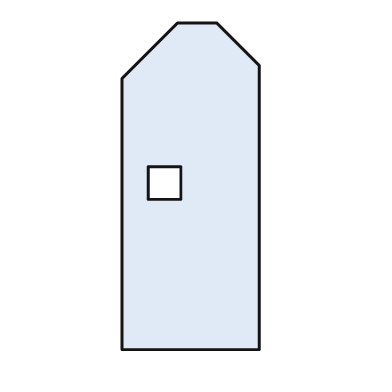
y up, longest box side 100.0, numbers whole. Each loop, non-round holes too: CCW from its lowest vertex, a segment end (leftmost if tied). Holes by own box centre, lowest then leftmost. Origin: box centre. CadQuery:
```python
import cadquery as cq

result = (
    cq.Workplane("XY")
    .moveTo(-21.0, -50.0)
    .lineTo(21.0, -50.0)
    .lineTo(21.0, 37.0)
    .lineTo(8.0, 50.0)
    .lineTo(-4.0, 50.0)
    .lineTo(-21.0, 33.0)
    .close()
    .moveTo(-13.0, -4.0)
    .lineTo(-3.0, -4.0)
    .lineTo(-3.0, 6.0)
    .lineTo(-13.0, 6.0)
    .close()
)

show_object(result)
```